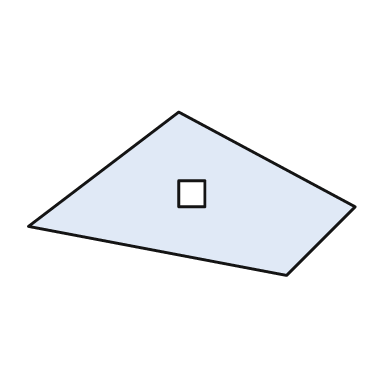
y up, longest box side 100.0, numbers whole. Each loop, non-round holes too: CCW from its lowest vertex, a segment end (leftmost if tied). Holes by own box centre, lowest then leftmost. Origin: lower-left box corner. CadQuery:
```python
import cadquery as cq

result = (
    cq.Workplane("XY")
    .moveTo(79.0, 0.0)
    .lineTo(100.0, 21.0)
    .lineTo(46.0, 50.0)
    .lineTo(0.0, 15.0)
    .close()
    .moveTo(46.0, 21.0)
    .lineTo(54.0, 21.0)
    .lineTo(54.0, 29.0)
    .lineTo(46.0, 29.0)
    .close()
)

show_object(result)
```